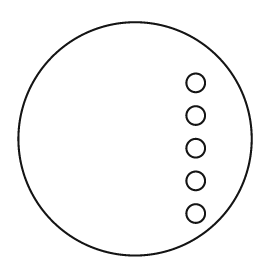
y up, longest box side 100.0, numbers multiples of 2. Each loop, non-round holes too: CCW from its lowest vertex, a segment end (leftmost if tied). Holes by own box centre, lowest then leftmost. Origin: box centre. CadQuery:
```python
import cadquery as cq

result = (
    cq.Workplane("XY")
    .moveTo(0.0, 0.0)
    .circle(50.0)
    .moveTo(26.0, -32.0)
    .circle(4.0)
    .moveTo(26.0, -18.0)
    .circle(4.0)
    .moveTo(26.0, -4.0)
    .circle(4.0)
    .moveTo(26.0, 10.0)
    .circle(4.0)
    .moveTo(26.0, 24.0)
    .circle(4.0)
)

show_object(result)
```